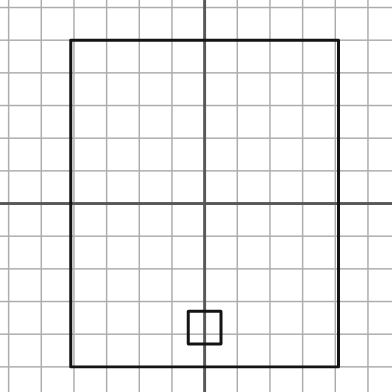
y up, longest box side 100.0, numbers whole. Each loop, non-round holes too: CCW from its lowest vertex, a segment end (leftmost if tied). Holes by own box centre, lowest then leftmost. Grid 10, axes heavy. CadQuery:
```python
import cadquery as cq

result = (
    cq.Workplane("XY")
    .moveTo(-41.0, -50.0)
    .lineTo(41.0, -50.0)
    .lineTo(41.0, 50.0)
    .lineTo(-41.0, 50.0)
    .close()
    .moveTo(-5.0, -43.0)
    .lineTo(5.0, -43.0)
    .lineTo(5.0, -33.0)
    .lineTo(-5.0, -33.0)
    .close()
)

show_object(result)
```